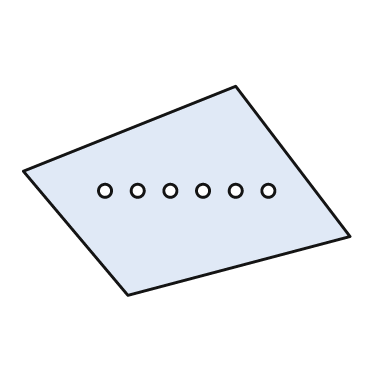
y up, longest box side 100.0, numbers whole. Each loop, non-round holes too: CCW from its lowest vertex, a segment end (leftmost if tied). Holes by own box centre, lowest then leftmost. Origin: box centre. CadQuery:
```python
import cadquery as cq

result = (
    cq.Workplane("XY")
    .moveTo(-18.0, -32.0)
    .lineTo(50.0, -14.0)
    .lineTo(15.0, 32.0)
    .lineTo(-50.0, 6.0)
    .close()
    .moveTo(-25.0, 0.0)
    .circle(2.0)
    .moveTo(-15.0, 0.0)
    .circle(2.0)
    .moveTo(-5.0, 0.0)
    .circle(2.0)
    .moveTo(5.0, 0.0)
    .circle(2.0)
    .moveTo(15.0, 0.0)
    .circle(2.0)
    .moveTo(25.0, 0.0)
    .circle(2.0)
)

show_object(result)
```